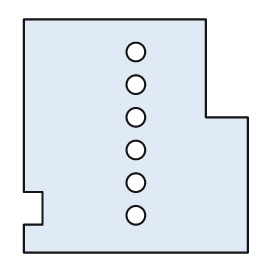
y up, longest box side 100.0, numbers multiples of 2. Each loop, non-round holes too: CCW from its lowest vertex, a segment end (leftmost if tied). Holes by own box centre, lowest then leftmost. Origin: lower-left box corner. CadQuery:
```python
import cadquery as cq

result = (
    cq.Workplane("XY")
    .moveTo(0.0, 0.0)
    .lineTo(96.0, 0.0)
    .lineTo(96.0, 58.0)
    .lineTo(78.0, 58.0)
    .lineTo(78.0, 100.0)
    .lineTo(0.0, 100.0)
    .lineTo(0.0, 26.0)
    .lineTo(8.0, 26.0)
    .lineTo(8.0, 12.0)
    .lineTo(0.0, 12.0)
    .close()
    .moveTo(48.0, 16.0)
    .circle(4.0)
    .moveTo(48.0, 30.0)
    .circle(4.0)
    .moveTo(48.0, 44.0)
    .circle(4.0)
    .moveTo(48.0, 58.0)
    .circle(4.0)
    .moveTo(48.0, 72.0)
    .circle(4.0)
    .moveTo(48.0, 86.0)
    .circle(4.0)
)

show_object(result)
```